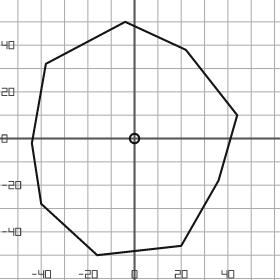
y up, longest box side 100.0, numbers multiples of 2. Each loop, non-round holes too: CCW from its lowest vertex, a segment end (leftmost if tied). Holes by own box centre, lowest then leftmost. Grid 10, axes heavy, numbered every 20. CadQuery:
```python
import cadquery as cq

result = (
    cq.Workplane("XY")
    .moveTo(-16.0, -50.0)
    .lineTo(20.0, -46.0)
    .lineTo(36.0, -18.0)
    .lineTo(44.0, 10.0)
    .lineTo(22.0, 38.0)
    .lineTo(-4.0, 50.0)
    .lineTo(-38.0, 32.0)
    .lineTo(-44.0, -2.0)
    .lineTo(-40.0, -28.0)
    .close()
    .moveTo(0.0, 0.0)
    .circle(2.0)
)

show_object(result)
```